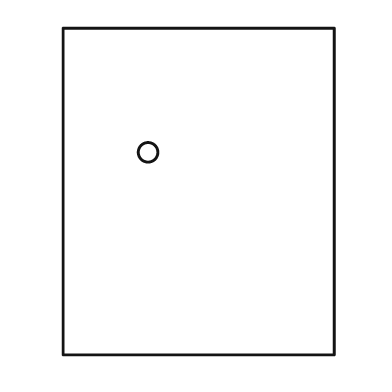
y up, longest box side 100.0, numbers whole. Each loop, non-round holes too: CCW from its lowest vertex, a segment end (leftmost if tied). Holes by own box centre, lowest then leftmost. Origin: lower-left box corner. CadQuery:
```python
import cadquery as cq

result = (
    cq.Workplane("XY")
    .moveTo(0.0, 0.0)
    .lineTo(83.0, 0.0)
    .lineTo(83.0, 100.0)
    .lineTo(0.0, 100.0)
    .close()
    .moveTo(26.0, 62.0)
    .circle(3.0)
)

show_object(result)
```